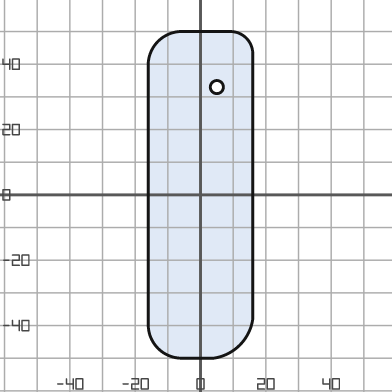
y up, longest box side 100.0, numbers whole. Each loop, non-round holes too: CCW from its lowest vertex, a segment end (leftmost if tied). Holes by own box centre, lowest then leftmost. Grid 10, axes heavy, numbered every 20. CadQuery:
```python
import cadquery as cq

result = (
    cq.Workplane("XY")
    .moveTo(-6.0, -50.0)
    .lineTo(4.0, -50.0)
    .threePointArc((12.0, -46.0), (16.0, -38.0))
    .lineTo(16.0, 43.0)
    .threePointArc((14.0, 48.0), (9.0, 50.0))
    .lineTo(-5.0, 50.0)
    .threePointArc((-13.0, 47.0), (-16.0, 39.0))
    .lineTo(-16.0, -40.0)
    .threePointArc((-13.0, -47.0), (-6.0, -50.0))
    .close()
    .moveTo(5.0, 33.0)
    .circle(2.0)
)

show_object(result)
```